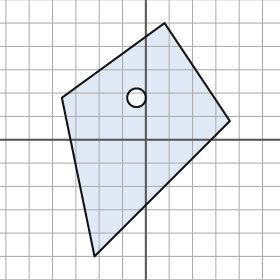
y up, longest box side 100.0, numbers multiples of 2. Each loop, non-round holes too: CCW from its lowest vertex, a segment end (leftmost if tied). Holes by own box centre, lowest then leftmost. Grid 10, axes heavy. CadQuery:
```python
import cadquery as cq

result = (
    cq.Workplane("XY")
    .moveTo(-22.0, -50.0)
    .lineTo(36.0, 8.0)
    .lineTo(8.0, 50.0)
    .lineTo(-36.0, 18.0)
    .close()
    .moveTo(-4.0, 18.0)
    .circle(4.0)
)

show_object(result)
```